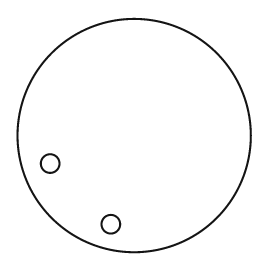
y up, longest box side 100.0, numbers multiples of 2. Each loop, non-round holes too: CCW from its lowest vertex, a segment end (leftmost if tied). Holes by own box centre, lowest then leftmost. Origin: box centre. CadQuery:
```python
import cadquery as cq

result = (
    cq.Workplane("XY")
    .moveTo(0.0, 0.0)
    .circle(50.0)
    .moveTo(-10.0, -38.0)
    .circle(4.0)
    .moveTo(-36.0, -12.0)
    .circle(4.0)
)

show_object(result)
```